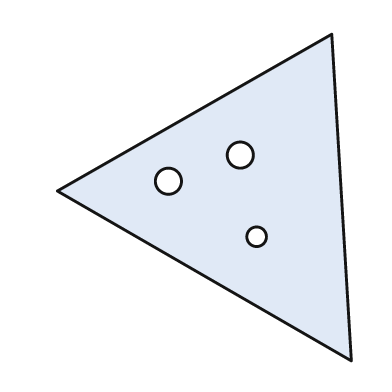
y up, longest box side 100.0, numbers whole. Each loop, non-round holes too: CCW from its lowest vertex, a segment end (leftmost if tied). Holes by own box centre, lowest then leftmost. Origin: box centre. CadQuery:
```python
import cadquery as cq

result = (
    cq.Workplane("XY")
    .moveTo(45.0, -50.0)
    .lineTo(39.0, 50.0)
    .lineTo(-45.0, 2.0)
    .close()
    .moveTo(16.0, -12.0)
    .circle(3.0)
    .moveTo(-11.0, 5.0)
    .circle(4.0)
    .moveTo(11.0, 13.0)
    .circle(4.0)
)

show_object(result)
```